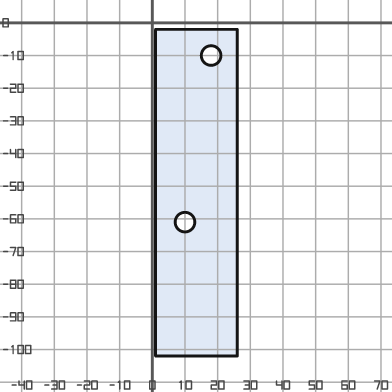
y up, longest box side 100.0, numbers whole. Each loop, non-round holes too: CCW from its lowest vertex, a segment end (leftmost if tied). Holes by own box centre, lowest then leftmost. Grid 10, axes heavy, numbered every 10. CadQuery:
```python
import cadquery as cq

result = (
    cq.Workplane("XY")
    .moveTo(1.0, -102.0)
    .lineTo(26.0, -102.0)
    .lineTo(26.0, -2.0)
    .lineTo(1.0, -2.0)
    .close()
    .moveTo(10.0, -61.0)
    .circle(3.0)
    .moveTo(18.0, -10.0)
    .circle(3.0)
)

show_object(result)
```